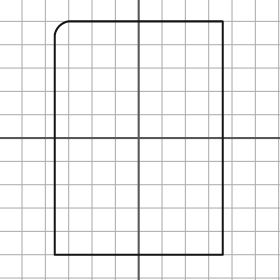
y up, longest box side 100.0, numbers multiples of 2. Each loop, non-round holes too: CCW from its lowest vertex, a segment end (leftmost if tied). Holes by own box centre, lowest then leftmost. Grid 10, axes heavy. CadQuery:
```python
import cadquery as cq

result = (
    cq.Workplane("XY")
    .moveTo(-36.0, -50.0)
    .lineTo(36.0, -50.0)
    .lineTo(36.0, 50.0)
    .lineTo(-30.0, 50.0)
    .threePointArc((-34.0, 48.0), (-36.0, 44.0))
    .close()
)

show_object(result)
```